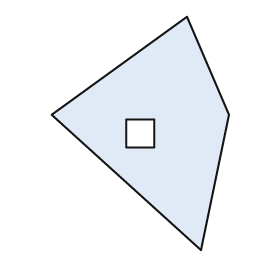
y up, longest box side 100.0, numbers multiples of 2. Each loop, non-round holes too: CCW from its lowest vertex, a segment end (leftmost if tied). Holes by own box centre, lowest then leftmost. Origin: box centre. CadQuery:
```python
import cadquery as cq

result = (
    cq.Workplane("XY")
    .moveTo(26.0, -50.0)
    .lineTo(38.0, 8.0)
    .lineTo(20.0, 50.0)
    .lineTo(-38.0, 8.0)
    .close()
    .moveTo(-6.0, -6.0)
    .lineTo(6.0, -6.0)
    .lineTo(6.0, 6.0)
    .lineTo(-6.0, 6.0)
    .close()
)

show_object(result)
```